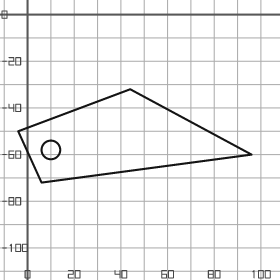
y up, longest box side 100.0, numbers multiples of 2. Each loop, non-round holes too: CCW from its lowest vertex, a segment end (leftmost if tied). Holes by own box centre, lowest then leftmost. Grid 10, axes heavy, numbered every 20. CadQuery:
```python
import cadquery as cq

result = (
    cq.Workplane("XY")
    .moveTo(6.0, -72.0)
    .lineTo(96.0, -60.0)
    .lineTo(44.0, -32.0)
    .lineTo(-4.0, -50.0)
    .close()
    .moveTo(10.0, -58.0)
    .circle(4.0)
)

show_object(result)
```